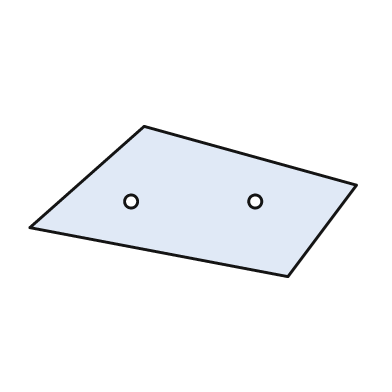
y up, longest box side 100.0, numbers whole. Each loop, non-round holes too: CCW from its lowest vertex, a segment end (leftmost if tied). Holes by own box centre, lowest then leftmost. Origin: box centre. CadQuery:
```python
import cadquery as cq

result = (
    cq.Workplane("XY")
    .moveTo(29.0, -23.0)
    .lineTo(50.0, 5.0)
    .lineTo(-15.0, 23.0)
    .lineTo(-50.0, -8.0)
    .close()
    .moveTo(-19.0, 0.0)
    .circle(2.0)
    .moveTo(19.0, 0.0)
    .circle(2.0)
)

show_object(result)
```